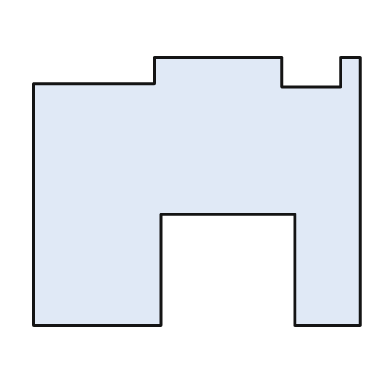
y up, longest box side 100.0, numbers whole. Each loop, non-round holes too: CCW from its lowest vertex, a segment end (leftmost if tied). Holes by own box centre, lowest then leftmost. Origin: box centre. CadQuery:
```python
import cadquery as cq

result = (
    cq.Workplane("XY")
    .moveTo(-50.0, -41.0)
    .lineTo(-11.0, -41.0)
    .lineTo(-11.0, -7.0)
    .lineTo(30.0, -7.0)
    .lineTo(30.0, -41.0)
    .lineTo(50.0, -41.0)
    .lineTo(50.0, 41.0)
    .lineTo(44.0, 41.0)
    .lineTo(44.0, 32.0)
    .lineTo(26.0, 32.0)
    .lineTo(26.0, 41.0)
    .lineTo(-13.0, 41.0)
    .lineTo(-13.0, 33.0)
    .lineTo(-50.0, 33.0)
    .close()
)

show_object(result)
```